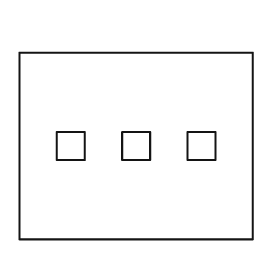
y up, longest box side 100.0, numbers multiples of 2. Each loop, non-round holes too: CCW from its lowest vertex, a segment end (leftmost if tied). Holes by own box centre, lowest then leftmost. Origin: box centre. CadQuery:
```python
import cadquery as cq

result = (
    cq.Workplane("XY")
    .moveTo(-50.0, -40.0)
    .lineTo(50.0, -40.0)
    .lineTo(50.0, 40.0)
    .lineTo(-50.0, 40.0)
    .close()
    .moveTo(-34.0, -6.0)
    .lineTo(-22.0, -6.0)
    .lineTo(-22.0, 6.0)
    .lineTo(-34.0, 6.0)
    .close()
    .moveTo(-6.0, -6.0)
    .lineTo(6.0, -6.0)
    .lineTo(6.0, 6.0)
    .lineTo(-6.0, 6.0)
    .close()
    .moveTo(22.0, -6.0)
    .lineTo(34.0, -6.0)
    .lineTo(34.0, 6.0)
    .lineTo(22.0, 6.0)
    .close()
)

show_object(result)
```